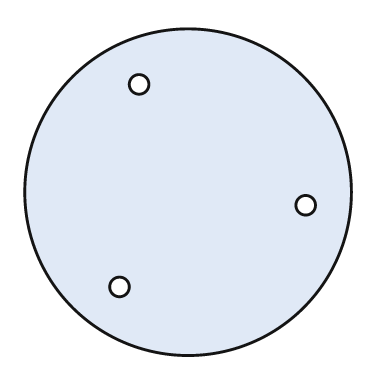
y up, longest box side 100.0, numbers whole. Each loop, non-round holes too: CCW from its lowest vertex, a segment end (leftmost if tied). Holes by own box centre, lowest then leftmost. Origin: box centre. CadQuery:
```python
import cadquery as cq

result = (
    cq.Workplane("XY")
    .moveTo(0.0, 0.0)
    .circle(50.0)
    .moveTo(-21.0, -29.0)
    .circle(3.0)
    .moveTo(36.0, -4.0)
    .circle(3.0)
    .moveTo(-15.0, 33.0)
    .circle(3.0)
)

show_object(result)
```